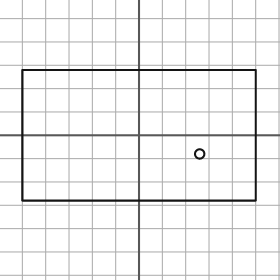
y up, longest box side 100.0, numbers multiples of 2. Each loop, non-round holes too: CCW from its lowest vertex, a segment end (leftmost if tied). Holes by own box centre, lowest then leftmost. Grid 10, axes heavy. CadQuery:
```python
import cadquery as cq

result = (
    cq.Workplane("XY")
    .moveTo(-50.0, -28.0)
    .lineTo(50.0, -28.0)
    .lineTo(50.0, 28.0)
    .lineTo(-50.0, 28.0)
    .close()
    .moveTo(26.0, -8.0)
    .circle(2.0)
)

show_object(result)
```